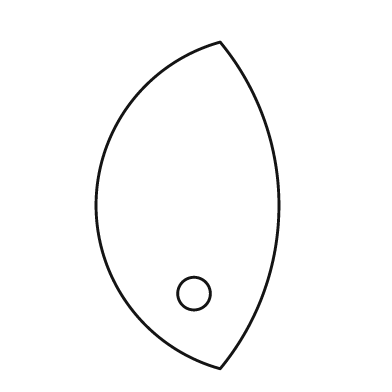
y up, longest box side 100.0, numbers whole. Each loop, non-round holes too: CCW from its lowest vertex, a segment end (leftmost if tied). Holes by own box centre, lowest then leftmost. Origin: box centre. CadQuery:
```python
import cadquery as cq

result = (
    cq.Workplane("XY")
    .moveTo(10.0, -50.0)
    .threePointArc((28.0, 0.0), (10.0, 50.0))
    .threePointArc((-28.0, 0.0), (10.0, -50.0))
    .close()
    .moveTo(2.0, -27.0)
    .circle(5.0)
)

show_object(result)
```